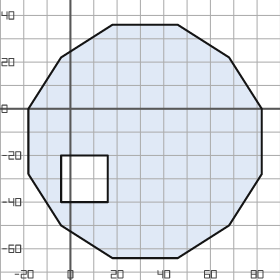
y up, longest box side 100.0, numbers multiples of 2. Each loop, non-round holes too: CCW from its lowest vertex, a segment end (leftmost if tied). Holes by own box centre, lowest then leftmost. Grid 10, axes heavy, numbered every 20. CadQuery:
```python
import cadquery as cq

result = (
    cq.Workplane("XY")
    .moveTo(18.0, -64.0)
    .lineTo(46.0, -64.0)
    .lineTo(68.0, -50.0)
    .lineTo(82.0, -28.0)
    .lineTo(82.0, 0.0)
    .lineTo(68.0, 22.0)
    .lineTo(46.0, 36.0)
    .lineTo(18.0, 36.0)
    .lineTo(-4.0, 22.0)
    .lineTo(-18.0, 0.0)
    .lineTo(-18.0, -28.0)
    .lineTo(-4.0, -50.0)
    .close()
    .moveTo(-4.0, -40.0)
    .lineTo(16.0, -40.0)
    .lineTo(16.0, -20.0)
    .lineTo(-4.0, -20.0)
    .close()
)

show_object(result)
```